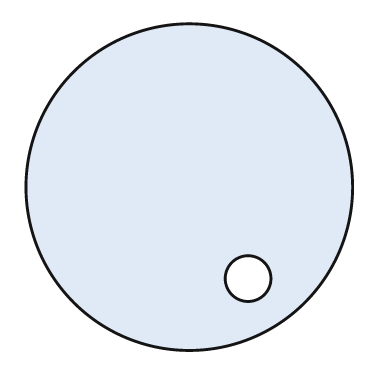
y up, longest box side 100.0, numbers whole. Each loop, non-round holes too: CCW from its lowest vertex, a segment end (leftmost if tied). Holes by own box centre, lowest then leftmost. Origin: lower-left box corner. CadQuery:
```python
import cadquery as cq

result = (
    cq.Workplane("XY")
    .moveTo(50.0, 50.0)
    .circle(50.0)
    .moveTo(68.0, 22.0)
    .circle(7.0)
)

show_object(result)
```